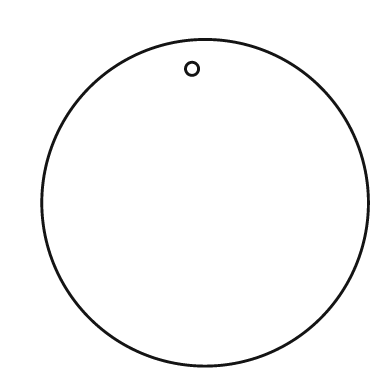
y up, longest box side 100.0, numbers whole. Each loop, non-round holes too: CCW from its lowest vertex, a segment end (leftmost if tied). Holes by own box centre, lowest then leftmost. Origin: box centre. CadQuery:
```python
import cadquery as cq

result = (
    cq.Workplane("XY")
    .moveTo(0.0, 0.0)
    .circle(50.0)
    .moveTo(-4.0, 41.0)
    .circle(2.0)
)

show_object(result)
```